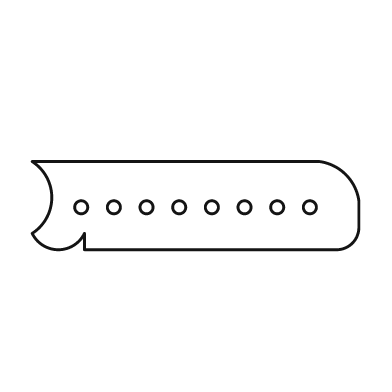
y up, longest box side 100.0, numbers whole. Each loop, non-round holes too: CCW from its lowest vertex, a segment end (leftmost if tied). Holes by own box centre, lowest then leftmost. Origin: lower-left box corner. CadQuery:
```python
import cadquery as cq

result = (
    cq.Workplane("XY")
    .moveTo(16.0, 0.0)
    .lineTo(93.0, 0.0)
    .threePointArc((98.0, 2.0), (100.0, 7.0))
    .lineTo(100.0, 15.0)
    .threePointArc((96.0, 23.0), (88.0, 27.0))
    .lineTo(0.0, 27.0)
    .threePointArc((6.0, 16.0), (0.0, 5.0))
    .threePointArc((8.0, 0.0), (16.0, 5.0))
    .close()
    .moveTo(15.0, 13.0)
    .circle(2.0)
    .moveTo(25.0, 13.0)
    .circle(2.0)
    .moveTo(35.0, 13.0)
    .circle(2.0)
    .moveTo(45.0, 13.0)
    .circle(2.0)
    .moveTo(55.0, 13.0)
    .circle(2.0)
    .moveTo(65.0, 13.0)
    .circle(2.0)
    .moveTo(75.0, 13.0)
    .circle(2.0)
    .moveTo(85.0, 13.0)
    .circle(2.0)
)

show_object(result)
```